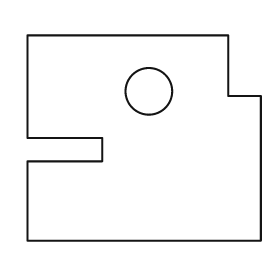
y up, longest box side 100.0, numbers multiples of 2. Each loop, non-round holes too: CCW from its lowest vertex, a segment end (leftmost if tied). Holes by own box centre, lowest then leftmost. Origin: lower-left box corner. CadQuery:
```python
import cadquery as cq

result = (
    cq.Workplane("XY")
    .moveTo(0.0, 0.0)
    .lineTo(100.0, 0.0)
    .lineTo(100.0, 62.0)
    .lineTo(86.0, 62.0)
    .lineTo(86.0, 88.0)
    .lineTo(0.0, 88.0)
    .lineTo(0.0, 44.0)
    .lineTo(32.0, 44.0)
    .lineTo(32.0, 34.0)
    .lineTo(0.0, 34.0)
    .close()
    .moveTo(52.0, 64.0)
    .circle(10.0)
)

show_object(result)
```